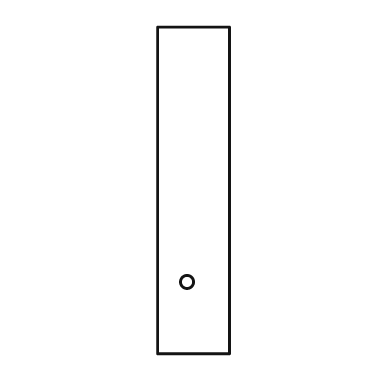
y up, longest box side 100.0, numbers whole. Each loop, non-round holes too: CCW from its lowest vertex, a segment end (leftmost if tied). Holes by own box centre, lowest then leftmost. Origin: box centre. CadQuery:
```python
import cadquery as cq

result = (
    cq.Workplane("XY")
    .moveTo(-11.0, -50.0)
    .lineTo(11.0, -50.0)
    .lineTo(11.0, 50.0)
    .lineTo(-11.0, 50.0)
    .close()
    .moveTo(-2.0, -28.0)
    .circle(2.0)
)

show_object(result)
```